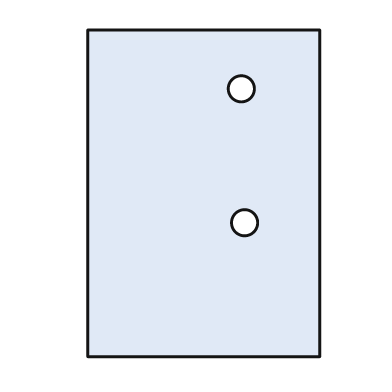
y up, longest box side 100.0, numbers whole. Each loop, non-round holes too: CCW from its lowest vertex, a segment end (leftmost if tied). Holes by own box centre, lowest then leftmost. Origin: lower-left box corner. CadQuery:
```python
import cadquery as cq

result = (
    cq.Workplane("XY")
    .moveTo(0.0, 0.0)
    .lineTo(71.0, 0.0)
    .lineTo(71.0, 100.0)
    .lineTo(0.0, 100.0)
    .close()
    .moveTo(48.0, 41.0)
    .circle(4.0)
    .moveTo(47.0, 82.0)
    .circle(4.0)
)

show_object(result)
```